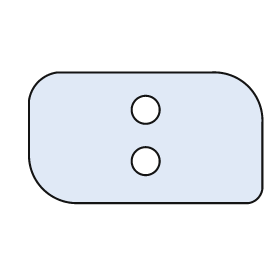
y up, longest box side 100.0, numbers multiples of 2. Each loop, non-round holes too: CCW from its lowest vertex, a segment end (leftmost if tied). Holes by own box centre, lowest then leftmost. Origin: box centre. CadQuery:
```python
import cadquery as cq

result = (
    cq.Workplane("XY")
    .moveTo(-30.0, -28.0)
    .lineTo(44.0, -28.0)
    .threePointArc((48.0, -26.0), (50.0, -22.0))
    .lineTo(50.0, 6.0)
    .threePointArc((44.0, 22.0), (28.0, 28.0))
    .lineTo(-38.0, 28.0)
    .threePointArc((-46.0, 24.0), (-50.0, 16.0))
    .lineTo(-50.0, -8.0)
    .threePointArc((-44.0, -22.0), (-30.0, -28.0))
    .close()
    .moveTo(0.0, -10.0)
    .circle(6.0)
    .moveTo(0.0, 12.0)
    .circle(6.0)
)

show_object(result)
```